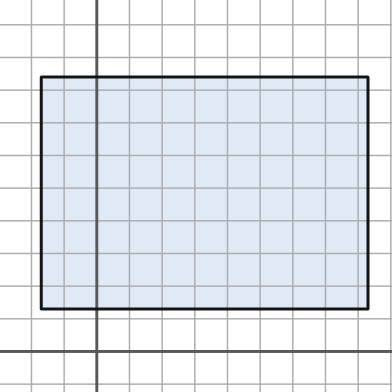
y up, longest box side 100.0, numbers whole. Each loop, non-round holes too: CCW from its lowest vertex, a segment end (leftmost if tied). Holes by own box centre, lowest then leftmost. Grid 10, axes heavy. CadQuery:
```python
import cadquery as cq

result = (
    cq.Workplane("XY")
    .moveTo(-17.0, 13.0)
    .lineTo(83.0, 13.0)
    .lineTo(83.0, 84.0)
    .lineTo(-17.0, 84.0)
    .close()
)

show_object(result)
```